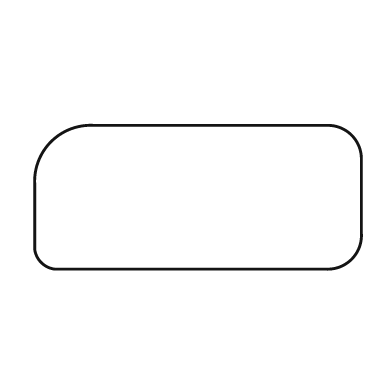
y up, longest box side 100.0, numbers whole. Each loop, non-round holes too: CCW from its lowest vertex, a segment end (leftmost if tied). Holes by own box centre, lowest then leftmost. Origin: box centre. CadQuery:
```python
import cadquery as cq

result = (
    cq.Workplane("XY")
    .moveTo(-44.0, -22.0)
    .lineTo(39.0, -22.0)
    .threePointArc((47.0, -19.0), (50.0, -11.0))
    .lineTo(50.0, 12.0)
    .threePointArc((47.0, 19.0), (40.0, 22.0))
    .lineTo(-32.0, 22.0)
    .threePointArc((-45.0, 17.0), (-50.0, 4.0))
    .lineTo(-50.0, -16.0)
    .threePointArc((-48.0, -20.0), (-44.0, -22.0))
    .close()
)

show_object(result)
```